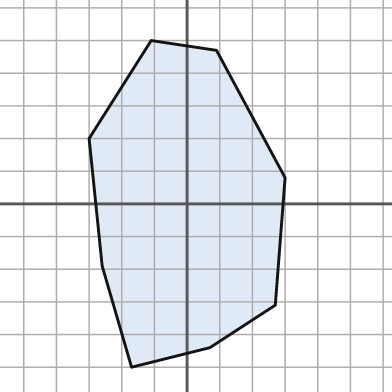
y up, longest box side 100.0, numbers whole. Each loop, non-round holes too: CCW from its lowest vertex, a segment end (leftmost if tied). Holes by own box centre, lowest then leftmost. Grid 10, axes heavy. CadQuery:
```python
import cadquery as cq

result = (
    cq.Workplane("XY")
    .moveTo(-17.0, -50.0)
    .lineTo(7.0, -44.0)
    .lineTo(27.0, -31.0)
    .lineTo(30.0, 8.0)
    .lineTo(9.0, 47.0)
    .lineTo(-11.0, 50.0)
    .lineTo(-30.0, 20.0)
    .lineTo(-26.0, -19.0)
    .close()
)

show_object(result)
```